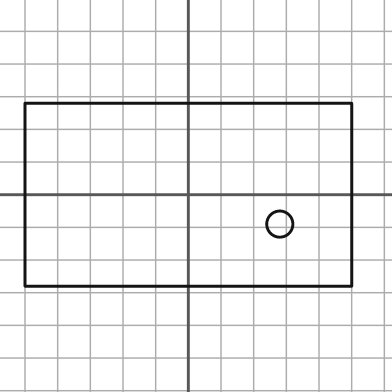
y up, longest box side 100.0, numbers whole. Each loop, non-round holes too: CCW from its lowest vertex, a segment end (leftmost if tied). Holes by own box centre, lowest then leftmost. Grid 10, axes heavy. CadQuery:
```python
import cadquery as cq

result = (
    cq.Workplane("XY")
    .moveTo(-50.0, -28.0)
    .lineTo(50.0, -28.0)
    .lineTo(50.0, 28.0)
    .lineTo(-50.0, 28.0)
    .close()
    .moveTo(28.0, -9.0)
    .circle(4.0)
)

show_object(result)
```